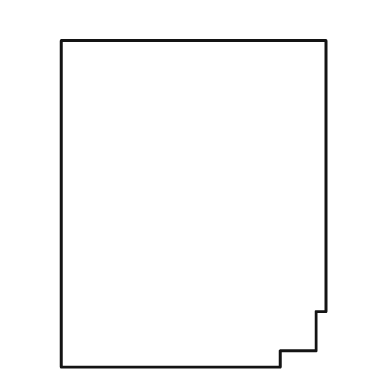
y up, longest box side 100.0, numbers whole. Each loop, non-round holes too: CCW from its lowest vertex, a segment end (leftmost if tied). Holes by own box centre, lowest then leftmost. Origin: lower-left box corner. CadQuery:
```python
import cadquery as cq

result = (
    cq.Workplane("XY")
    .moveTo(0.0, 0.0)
    .lineTo(67.0, 0.0)
    .lineTo(67.0, 5.0)
    .lineTo(78.0, 5.0)
    .lineTo(78.0, 17.0)
    .lineTo(81.0, 17.0)
    .lineTo(81.0, 100.0)
    .lineTo(0.0, 100.0)
    .close()
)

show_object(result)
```